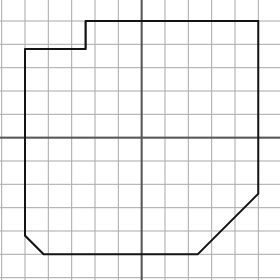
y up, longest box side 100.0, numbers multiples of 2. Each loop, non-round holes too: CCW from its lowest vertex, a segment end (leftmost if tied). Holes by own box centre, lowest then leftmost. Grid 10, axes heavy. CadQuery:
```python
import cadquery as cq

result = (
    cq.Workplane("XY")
    .moveTo(-42.0, -50.0)
    .lineTo(24.0, -50.0)
    .lineTo(50.0, -24.0)
    .lineTo(50.0, 50.0)
    .lineTo(-24.0, 50.0)
    .lineTo(-24.0, 38.0)
    .lineTo(-50.0, 38.0)
    .lineTo(-50.0, -42.0)
    .close()
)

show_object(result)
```